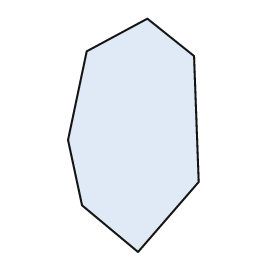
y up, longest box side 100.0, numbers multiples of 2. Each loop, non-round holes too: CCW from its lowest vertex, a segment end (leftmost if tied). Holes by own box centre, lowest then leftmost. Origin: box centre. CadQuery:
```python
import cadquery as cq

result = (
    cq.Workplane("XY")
    .moveTo(2.0, -50.0)
    .lineTo(28.0, -20.0)
    .lineTo(26.0, 34.0)
    .lineTo(6.0, 50.0)
    .lineTo(-20.0, 36.0)
    .lineTo(-28.0, -2.0)
    .lineTo(-22.0, -30.0)
    .close()
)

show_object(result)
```